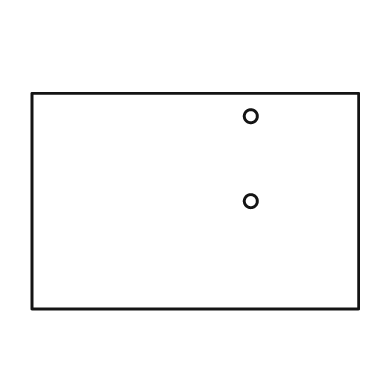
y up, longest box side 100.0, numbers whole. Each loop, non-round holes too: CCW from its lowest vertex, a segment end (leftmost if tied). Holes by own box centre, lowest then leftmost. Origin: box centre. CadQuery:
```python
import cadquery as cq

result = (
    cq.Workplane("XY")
    .moveTo(-50.0, -33.0)
    .lineTo(50.0, -33.0)
    .lineTo(50.0, 33.0)
    .lineTo(-50.0, 33.0)
    .close()
    .moveTo(17.0, 0.0)
    .circle(2.0)
    .moveTo(17.0, 26.0)
    .circle(2.0)
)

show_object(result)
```